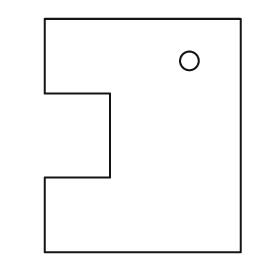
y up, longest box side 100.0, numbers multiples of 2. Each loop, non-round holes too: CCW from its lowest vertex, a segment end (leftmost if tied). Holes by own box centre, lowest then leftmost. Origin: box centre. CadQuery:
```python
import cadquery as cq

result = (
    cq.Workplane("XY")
    .moveTo(-42.0, -50.0)
    .lineTo(42.0, -50.0)
    .lineTo(42.0, 50.0)
    .lineTo(-42.0, 50.0)
    .lineTo(-42.0, 18.0)
    .lineTo(-14.0, 18.0)
    .lineTo(-14.0, -18.0)
    .lineTo(-42.0, -18.0)
    .close()
    .moveTo(20.0, 32.0)
    .circle(4.0)
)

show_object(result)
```